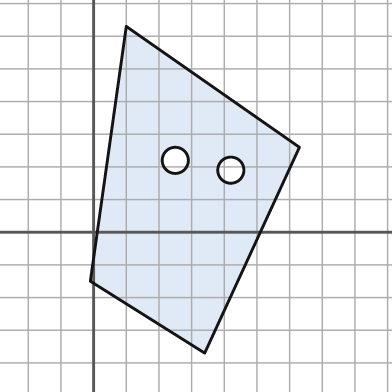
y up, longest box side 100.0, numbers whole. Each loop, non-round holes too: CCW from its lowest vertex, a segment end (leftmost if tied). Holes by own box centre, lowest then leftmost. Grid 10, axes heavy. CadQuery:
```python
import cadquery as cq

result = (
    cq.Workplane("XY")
    .moveTo(34.0, -37.0)
    .lineTo(63.0, 26.0)
    .lineTo(10.0, 63.0)
    .lineTo(-1.0, -15.0)
    .close()
    .moveTo(42.0, 19.0)
    .circle(4.0)
    .moveTo(25.0, 22.0)
    .circle(4.0)
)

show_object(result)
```